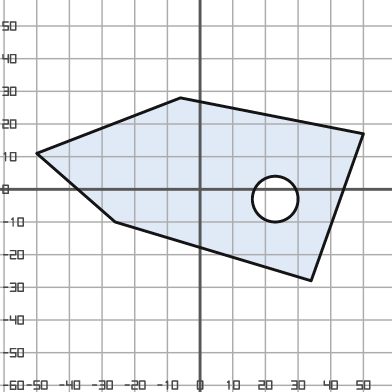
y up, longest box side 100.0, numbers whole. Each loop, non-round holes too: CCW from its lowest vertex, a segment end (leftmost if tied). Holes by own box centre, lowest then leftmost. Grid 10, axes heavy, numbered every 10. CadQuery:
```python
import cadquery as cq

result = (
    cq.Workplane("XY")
    .moveTo(34.0, -28.0)
    .lineTo(50.0, 17.0)
    .lineTo(-6.0, 28.0)
    .lineTo(-50.0, 11.0)
    .lineTo(-26.0, -10.0)
    .close()
    .moveTo(23.0, -3.0)
    .circle(7.0)
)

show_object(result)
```